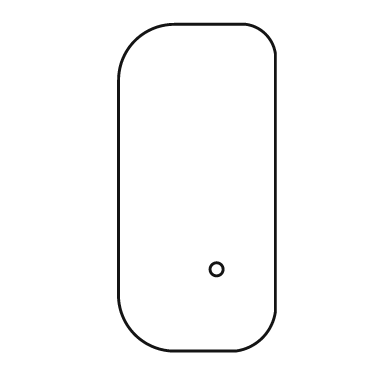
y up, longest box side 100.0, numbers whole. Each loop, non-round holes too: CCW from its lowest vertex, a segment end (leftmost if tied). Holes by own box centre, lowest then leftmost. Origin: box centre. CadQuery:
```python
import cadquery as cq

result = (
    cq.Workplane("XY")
    .moveTo(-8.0, -50.0)
    .lineTo(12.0, -50.0)
    .threePointArc((20.0, -46.0), (24.0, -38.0))
    .lineTo(24.0, 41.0)
    .threePointArc((21.0, 47.0), (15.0, 50.0))
    .lineTo(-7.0, 50.0)
    .threePointArc((-19.0, 45.0), (-24.0, 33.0))
    .lineTo(-24.0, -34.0)
    .threePointArc((-19.0, -45.0), (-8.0, -50.0))
    .close()
    .moveTo(6.0, -25.0)
    .circle(2.0)
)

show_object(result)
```